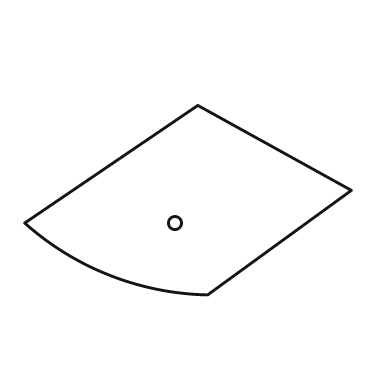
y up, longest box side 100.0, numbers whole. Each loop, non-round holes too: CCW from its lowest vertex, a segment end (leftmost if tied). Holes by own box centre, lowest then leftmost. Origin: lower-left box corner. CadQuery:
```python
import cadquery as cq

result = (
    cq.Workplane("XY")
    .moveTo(56.0, 0.0)
    .lineTo(100.0, 32.0)
    .lineTo(53.0, 58.0)
    .lineTo(0.0, 22.0)
    .threePointArc((26.0, 6.0), (56.0, 0.0))
    .close()
    .moveTo(46.0, 22.0)
    .circle(2.0)
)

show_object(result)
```